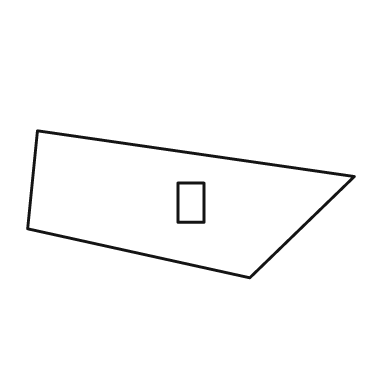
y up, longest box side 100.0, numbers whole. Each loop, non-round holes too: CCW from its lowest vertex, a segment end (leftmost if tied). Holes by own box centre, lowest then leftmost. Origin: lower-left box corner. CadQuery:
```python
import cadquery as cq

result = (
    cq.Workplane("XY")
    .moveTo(68.0, 0.0)
    .lineTo(100.0, 31.0)
    .lineTo(3.0, 45.0)
    .lineTo(0.0, 15.0)
    .close()
    .moveTo(46.0, 17.0)
    .lineTo(54.0, 17.0)
    .lineTo(54.0, 29.0)
    .lineTo(46.0, 29.0)
    .close()
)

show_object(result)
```